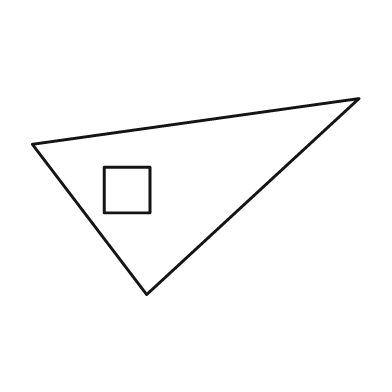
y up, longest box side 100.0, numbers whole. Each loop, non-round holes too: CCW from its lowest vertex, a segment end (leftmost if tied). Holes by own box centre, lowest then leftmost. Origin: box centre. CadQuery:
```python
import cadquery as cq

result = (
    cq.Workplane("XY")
    .moveTo(-15.0, -30.0)
    .lineTo(50.0, 30.0)
    .lineTo(-50.0, 16.0)
    .close()
    .moveTo(-28.0, -5.0)
    .lineTo(-14.0, -5.0)
    .lineTo(-14.0, 9.0)
    .lineTo(-28.0, 9.0)
    .close()
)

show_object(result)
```